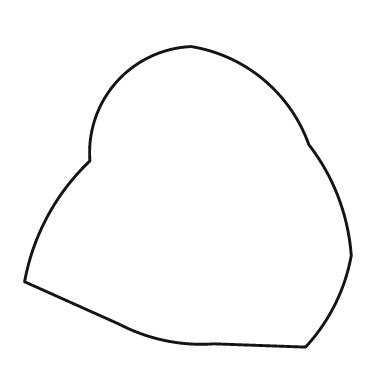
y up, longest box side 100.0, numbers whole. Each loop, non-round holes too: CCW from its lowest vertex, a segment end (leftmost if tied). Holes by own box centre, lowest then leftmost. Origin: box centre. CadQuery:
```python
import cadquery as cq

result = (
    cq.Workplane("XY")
    .moveTo(36.0, -46.0)
    .threePointArc((45.0, -33.0), (50.0, -18.0))
    .threePointArc((46.0, 0.0), (37.0, 16.0))
    .threePointArc((23.0, 36.0), (1.0, 46.0))
    .threePointArc((-22.0, 35.0), (-30.0, 11.0))
    .threePointArc((-43.0, -6.0), (-50.0, -26.0))
    .lineTo(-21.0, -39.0)
    .threePointArc((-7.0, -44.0), (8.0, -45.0))
    .close()
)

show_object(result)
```